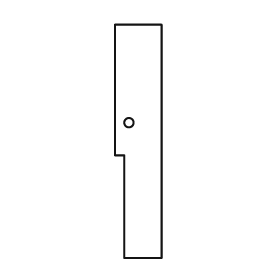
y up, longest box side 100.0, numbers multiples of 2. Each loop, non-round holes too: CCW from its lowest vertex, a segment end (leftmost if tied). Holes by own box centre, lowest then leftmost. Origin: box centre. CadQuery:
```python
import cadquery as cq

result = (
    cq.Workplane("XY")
    .moveTo(-6.0, -50.0)
    .lineTo(10.0, -50.0)
    .lineTo(10.0, 50.0)
    .lineTo(-10.0, 50.0)
    .lineTo(-10.0, -6.0)
    .lineTo(-6.0, -6.0)
    .close()
    .moveTo(-4.0, 8.0)
    .circle(2.0)
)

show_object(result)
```